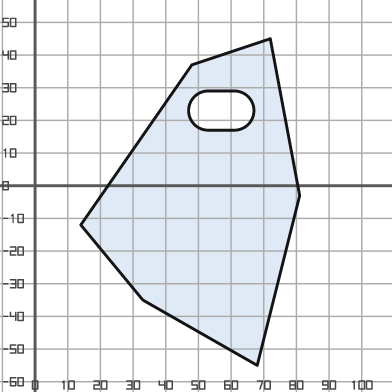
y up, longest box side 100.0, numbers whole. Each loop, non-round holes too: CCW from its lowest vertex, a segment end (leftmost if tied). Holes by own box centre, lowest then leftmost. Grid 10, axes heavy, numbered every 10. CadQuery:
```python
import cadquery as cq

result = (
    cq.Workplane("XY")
    .moveTo(68.0, -55.0)
    .lineTo(81.0, -3.0)
    .lineTo(72.0, 45.0)
    .lineTo(48.0, 37.0)
    .lineTo(14.0, -12.0)
    .lineTo(33.0, -35.0)
    .close()
    .moveTo(53.0, 17.0)
    .lineTo(61.0, 17.0)
    .threePointArc((67.0, 23.0), (61.0, 29.0))
    .lineTo(53.0, 29.0)
    .threePointArc((47.0, 23.0), (53.0, 17.0))
    .close()
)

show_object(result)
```